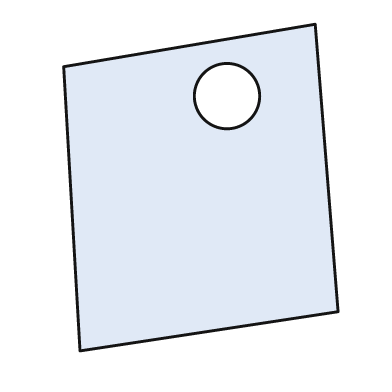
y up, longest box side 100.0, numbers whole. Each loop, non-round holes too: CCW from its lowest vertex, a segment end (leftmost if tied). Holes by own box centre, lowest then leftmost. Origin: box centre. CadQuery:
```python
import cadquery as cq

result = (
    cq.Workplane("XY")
    .moveTo(-37.0, -50.0)
    .lineTo(42.0, -38.0)
    .lineTo(35.0, 50.0)
    .lineTo(-42.0, 37.0)
    .close()
    .moveTo(8.0, 28.0)
    .circle(10.0)
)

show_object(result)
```